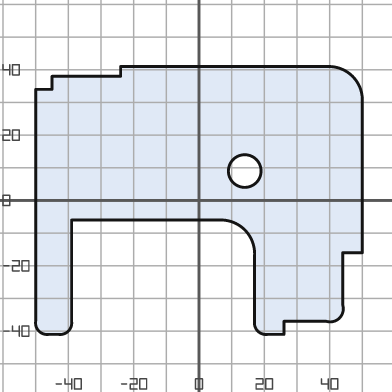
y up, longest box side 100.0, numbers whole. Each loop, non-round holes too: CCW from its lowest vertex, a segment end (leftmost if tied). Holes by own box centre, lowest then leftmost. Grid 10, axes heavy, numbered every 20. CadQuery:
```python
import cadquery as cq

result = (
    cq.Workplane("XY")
    .moveTo(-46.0, -41.0)
    .lineTo(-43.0, -41.0)
    .threePointArc((-40.0, -40.0), (-39.0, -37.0))
    .lineTo(-39.0, -6.0)
    .lineTo(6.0, -6.0)
    .threePointArc((14.0, -9.0), (17.0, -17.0))
    .lineTo(17.0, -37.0)
    .threePointArc((18.0, -40.0), (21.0, -41.0))
    .lineTo(26.0, -41.0)
    .lineTo(26.0, -37.0)
    .lineTo(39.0, -37.0)
    .threePointArc((43.0, -36.0), (44.0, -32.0))
    .lineTo(44.0, -16.0)
    .lineTo(50.0, -16.0)
    .lineTo(50.0, 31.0)
    .threePointArc((47.0, 38.0), (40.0, 41.0))
    .lineTo(-24.0, 41.0)
    .lineTo(-24.0, 38.0)
    .lineTo(-45.0, 38.0)
    .lineTo(-45.0, 34.0)
    .lineTo(-50.0, 34.0)
    .lineTo(-50.0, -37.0)
    .threePointArc((-49.0, -40.0), (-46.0, -41.0))
    .close()
    .moveTo(14.0, 9.0)
    .circle(5.0)
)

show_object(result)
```